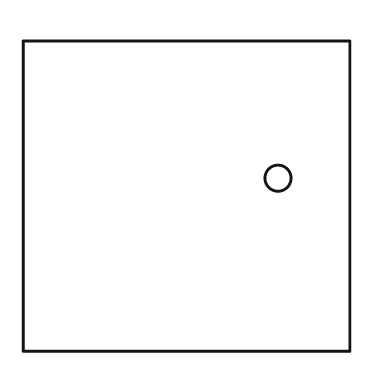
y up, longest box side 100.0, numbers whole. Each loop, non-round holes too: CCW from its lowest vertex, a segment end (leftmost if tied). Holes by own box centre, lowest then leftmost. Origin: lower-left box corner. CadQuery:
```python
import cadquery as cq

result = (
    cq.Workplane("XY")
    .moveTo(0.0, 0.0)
    .lineTo(100.0, 0.0)
    .lineTo(100.0, 95.0)
    .lineTo(0.0, 95.0)
    .close()
    .moveTo(78.0, 53.0)
    .circle(4.0)
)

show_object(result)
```